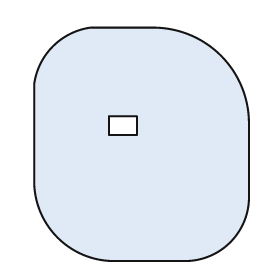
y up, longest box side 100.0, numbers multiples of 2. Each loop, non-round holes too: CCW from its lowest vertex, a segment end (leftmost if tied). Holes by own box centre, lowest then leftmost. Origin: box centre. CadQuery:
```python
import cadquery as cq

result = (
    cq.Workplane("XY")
    .moveTo(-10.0, -50.0)
    .lineTo(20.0, -50.0)
    .threePointArc((38.0, -42.0), (46.0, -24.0))
    .lineTo(46.0, 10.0)
    .threePointArc((34.0, 38.0), (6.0, 50.0))
    .lineTo(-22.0, 50.0)
    .threePointArc((-38.0, 42.0), (-46.0, 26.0))
    .lineTo(-46.0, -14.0)
    .threePointArc((-36.0, -40.0), (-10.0, -50.0))
    .close()
    .moveTo(-14.0, 4.0)
    .lineTo(-2.0, 4.0)
    .lineTo(-2.0, 12.0)
    .lineTo(-14.0, 12.0)
    .close()
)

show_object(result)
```